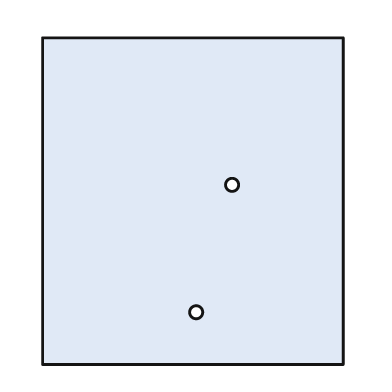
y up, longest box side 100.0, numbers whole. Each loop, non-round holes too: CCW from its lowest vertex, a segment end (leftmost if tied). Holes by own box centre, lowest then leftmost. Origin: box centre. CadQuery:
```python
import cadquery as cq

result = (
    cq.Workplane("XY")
    .moveTo(-46.0, -50.0)
    .lineTo(46.0, -50.0)
    .lineTo(46.0, 50.0)
    .lineTo(-46.0, 50.0)
    .close()
    .moveTo(1.0, -34.0)
    .circle(2.0)
    .moveTo(12.0, 5.0)
    .circle(2.0)
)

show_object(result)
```